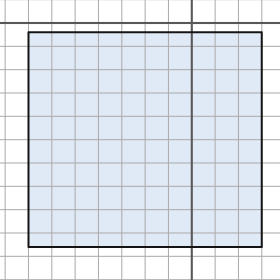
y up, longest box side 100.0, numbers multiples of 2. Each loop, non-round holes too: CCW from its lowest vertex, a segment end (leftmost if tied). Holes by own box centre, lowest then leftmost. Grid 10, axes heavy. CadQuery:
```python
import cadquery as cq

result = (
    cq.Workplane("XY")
    .moveTo(-70.0, -96.0)
    .lineTo(30.0, -96.0)
    .lineTo(30.0, -4.0)
    .lineTo(-70.0, -4.0)
    .close()
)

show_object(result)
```